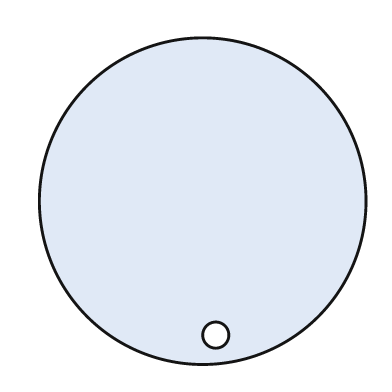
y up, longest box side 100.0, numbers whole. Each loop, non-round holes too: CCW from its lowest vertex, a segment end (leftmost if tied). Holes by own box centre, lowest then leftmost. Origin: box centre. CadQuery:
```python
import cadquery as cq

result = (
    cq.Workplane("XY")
    .moveTo(0.0, 0.0)
    .circle(50.0)
    .moveTo(4.0, -41.0)
    .circle(4.0)
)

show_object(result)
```